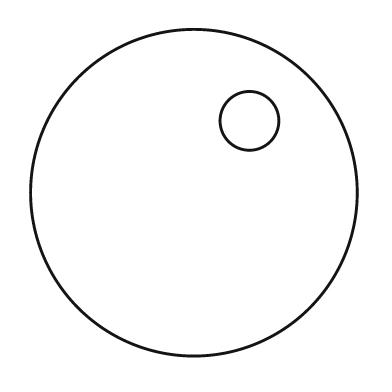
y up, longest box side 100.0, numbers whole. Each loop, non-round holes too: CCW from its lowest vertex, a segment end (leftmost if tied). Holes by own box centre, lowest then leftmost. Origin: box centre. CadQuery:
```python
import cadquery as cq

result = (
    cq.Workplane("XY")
    .moveTo(0.0, 0.0)
    .circle(50.0)
    .moveTo(17.0, 22.0)
    .circle(9.0)
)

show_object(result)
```